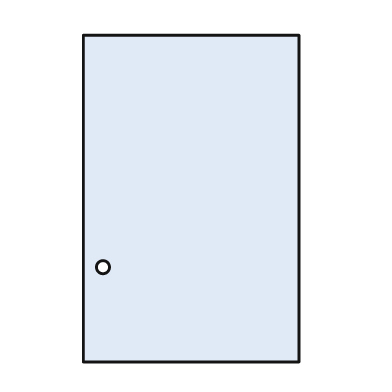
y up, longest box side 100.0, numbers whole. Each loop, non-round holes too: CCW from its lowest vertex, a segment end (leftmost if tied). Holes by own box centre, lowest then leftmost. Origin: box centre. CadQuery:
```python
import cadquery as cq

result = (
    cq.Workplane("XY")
    .moveTo(-33.0, -50.0)
    .lineTo(33.0, -50.0)
    .lineTo(33.0, 50.0)
    .lineTo(-33.0, 50.0)
    .close()
    .moveTo(-27.0, -21.0)
    .circle(2.0)
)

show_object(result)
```